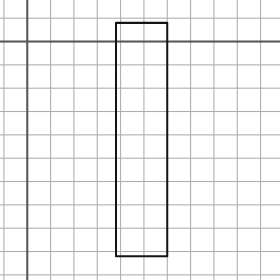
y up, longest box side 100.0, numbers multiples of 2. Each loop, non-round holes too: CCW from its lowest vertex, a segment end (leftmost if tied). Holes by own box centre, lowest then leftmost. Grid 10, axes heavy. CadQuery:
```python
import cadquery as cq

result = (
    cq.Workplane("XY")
    .moveTo(38.0, -92.0)
    .lineTo(60.0, -92.0)
    .lineTo(60.0, 8.0)
    .lineTo(38.0, 8.0)
    .close()
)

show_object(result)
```